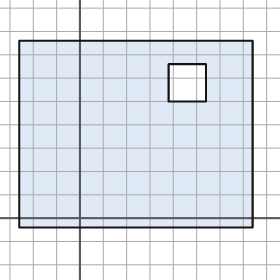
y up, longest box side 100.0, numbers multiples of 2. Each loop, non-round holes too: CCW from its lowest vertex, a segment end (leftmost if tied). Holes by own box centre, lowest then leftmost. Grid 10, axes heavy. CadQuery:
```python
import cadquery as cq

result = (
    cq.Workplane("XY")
    .moveTo(-26.0, -4.0)
    .lineTo(74.0, -4.0)
    .lineTo(74.0, 76.0)
    .lineTo(-26.0, 76.0)
    .close()
    .moveTo(38.0, 50.0)
    .lineTo(54.0, 50.0)
    .lineTo(54.0, 66.0)
    .lineTo(38.0, 66.0)
    .close()
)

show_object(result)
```